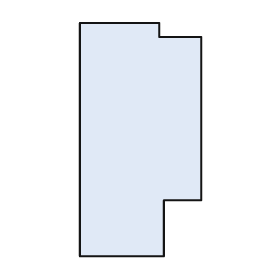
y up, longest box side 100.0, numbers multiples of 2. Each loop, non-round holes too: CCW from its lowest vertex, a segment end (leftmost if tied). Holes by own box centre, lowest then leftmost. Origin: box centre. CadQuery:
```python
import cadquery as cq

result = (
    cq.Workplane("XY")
    .moveTo(-26.0, -50.0)
    .lineTo(10.0, -50.0)
    .lineTo(10.0, -26.0)
    .lineTo(26.0, -26.0)
    .lineTo(26.0, 44.0)
    .lineTo(8.0, 44.0)
    .lineTo(8.0, 50.0)
    .lineTo(-26.0, 50.0)
    .close()
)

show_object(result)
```